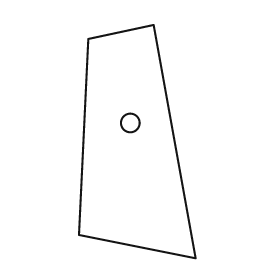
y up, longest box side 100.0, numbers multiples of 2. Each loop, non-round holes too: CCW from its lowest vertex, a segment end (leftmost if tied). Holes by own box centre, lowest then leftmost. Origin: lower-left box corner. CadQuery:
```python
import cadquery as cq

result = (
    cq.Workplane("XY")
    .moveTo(50.0, 0.0)
    .lineTo(32.0, 100.0)
    .lineTo(4.0, 94.0)
    .lineTo(0.0, 10.0)
    .close()
    .moveTo(22.0, 58.0)
    .circle(4.0)
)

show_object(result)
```